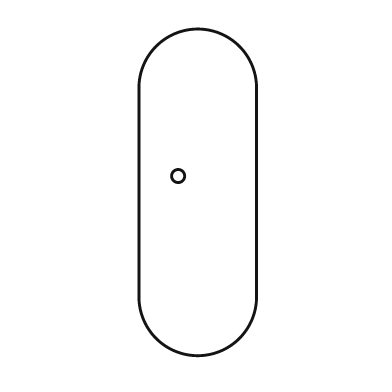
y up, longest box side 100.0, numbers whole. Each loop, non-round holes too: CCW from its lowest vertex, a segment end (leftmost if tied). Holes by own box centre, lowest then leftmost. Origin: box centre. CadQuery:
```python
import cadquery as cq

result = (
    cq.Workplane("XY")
    .moveTo(-18.0, -32.0)
    .threePointArc((0.0, -50.0), (18.0, -32.0))
    .lineTo(18.0, 32.0)
    .threePointArc((0.0, 50.0), (-18.0, 32.0))
    .close()
    .moveTo(-6.0, 5.0)
    .circle(2.0)
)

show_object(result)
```